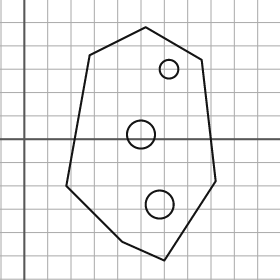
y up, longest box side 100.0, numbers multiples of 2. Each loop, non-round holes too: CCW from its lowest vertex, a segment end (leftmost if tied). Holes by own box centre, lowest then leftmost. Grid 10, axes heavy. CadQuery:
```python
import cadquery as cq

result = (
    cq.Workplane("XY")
    .moveTo(60.0, -52.0)
    .lineTo(82.0, -18.0)
    .lineTo(76.0, 34.0)
    .lineTo(52.0, 48.0)
    .lineTo(28.0, 36.0)
    .lineTo(18.0, -20.0)
    .lineTo(42.0, -44.0)
    .close()
    .moveTo(58.0, -28.0)
    .circle(6.0)
    .moveTo(50.0, 2.0)
    .circle(6.0)
    .moveTo(62.0, 30.0)
    .circle(4.0)
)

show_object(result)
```